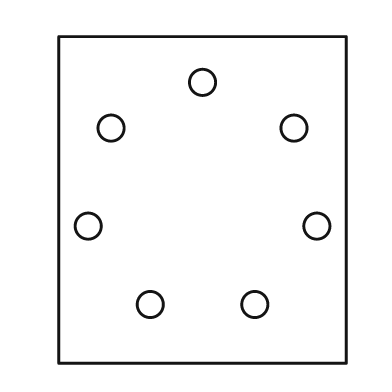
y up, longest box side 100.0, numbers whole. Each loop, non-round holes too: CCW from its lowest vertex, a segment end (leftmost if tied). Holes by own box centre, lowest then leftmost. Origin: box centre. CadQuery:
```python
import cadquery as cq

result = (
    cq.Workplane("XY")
    .moveTo(-44.0, -50.0)
    .lineTo(44.0, -50.0)
    .lineTo(44.0, 50.0)
    .lineTo(-44.0, 50.0)
    .close()
    .moveTo(-16.0, -32.0)
    .circle(4.0)
    .moveTo(16.0, -32.0)
    .circle(4.0)
    .moveTo(-35.0, -8.0)
    .circle(4.0)
    .moveTo(35.0, -8.0)
    .circle(4.0)
    .moveTo(-28.0, 22.0)
    .circle(4.0)
    .moveTo(28.0, 22.0)
    .circle(4.0)
    .moveTo(0.0, 36.0)
    .circle(4.0)
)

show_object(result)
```